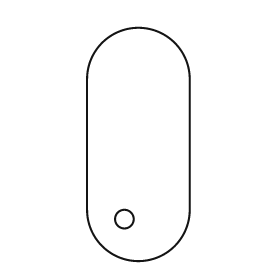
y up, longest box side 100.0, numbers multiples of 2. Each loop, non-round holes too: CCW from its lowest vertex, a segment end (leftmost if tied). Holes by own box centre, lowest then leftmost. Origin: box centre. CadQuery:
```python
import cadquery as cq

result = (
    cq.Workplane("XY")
    .moveTo(-22.0, -28.0)
    .threePointArc((0.0, -50.0), (22.0, -28.0))
    .lineTo(22.0, 28.0)
    .threePointArc((0.0, 50.0), (-22.0, 28.0))
    .close()
    .moveTo(-6.0, -32.0)
    .circle(4.0)
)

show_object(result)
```